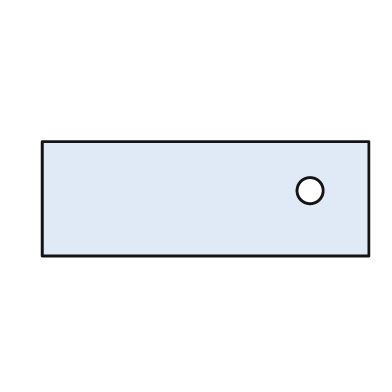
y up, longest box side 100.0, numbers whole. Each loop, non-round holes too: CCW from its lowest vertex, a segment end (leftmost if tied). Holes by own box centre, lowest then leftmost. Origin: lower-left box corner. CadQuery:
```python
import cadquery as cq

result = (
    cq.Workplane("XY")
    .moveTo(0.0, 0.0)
    .lineTo(100.0, 0.0)
    .lineTo(100.0, 35.0)
    .lineTo(0.0, 35.0)
    .close()
    .moveTo(82.0, 20.0)
    .circle(4.0)
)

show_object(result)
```